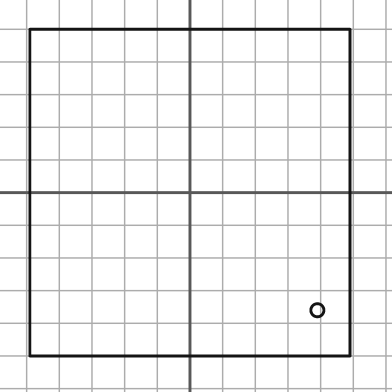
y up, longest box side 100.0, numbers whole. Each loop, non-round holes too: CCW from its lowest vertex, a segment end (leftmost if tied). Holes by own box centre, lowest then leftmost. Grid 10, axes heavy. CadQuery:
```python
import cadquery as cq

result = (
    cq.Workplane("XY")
    .moveTo(-49.0, -50.0)
    .lineTo(49.0, -50.0)
    .lineTo(49.0, 50.0)
    .lineTo(-49.0, 50.0)
    .close()
    .moveTo(39.0, -36.0)
    .circle(2.0)
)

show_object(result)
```